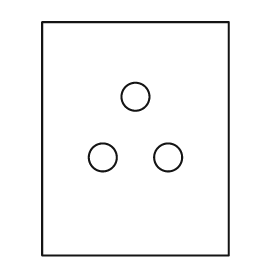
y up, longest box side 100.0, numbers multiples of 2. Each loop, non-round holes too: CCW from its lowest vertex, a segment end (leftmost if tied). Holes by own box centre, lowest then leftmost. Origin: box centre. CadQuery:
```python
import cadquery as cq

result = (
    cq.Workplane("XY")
    .moveTo(-40.0, -50.0)
    .lineTo(40.0, -50.0)
    .lineTo(40.0, 50.0)
    .lineTo(-40.0, 50.0)
    .close()
    .moveTo(-14.0, -8.0)
    .circle(6.0)
    .moveTo(14.0, -8.0)
    .circle(6.0)
    .moveTo(0.0, 18.0)
    .circle(6.0)
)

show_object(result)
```